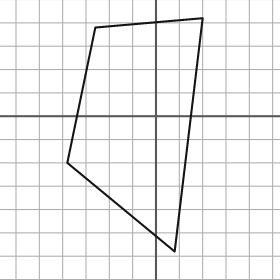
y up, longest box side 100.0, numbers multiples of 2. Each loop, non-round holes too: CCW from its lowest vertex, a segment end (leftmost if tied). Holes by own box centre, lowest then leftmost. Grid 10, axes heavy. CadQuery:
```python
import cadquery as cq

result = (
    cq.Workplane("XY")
    .moveTo(8.0, -58.0)
    .lineTo(20.0, 42.0)
    .lineTo(-26.0, 38.0)
    .lineTo(-38.0, -20.0)
    .close()
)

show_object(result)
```